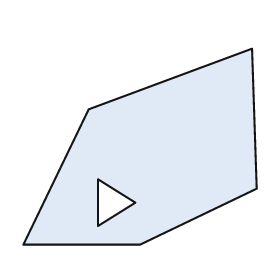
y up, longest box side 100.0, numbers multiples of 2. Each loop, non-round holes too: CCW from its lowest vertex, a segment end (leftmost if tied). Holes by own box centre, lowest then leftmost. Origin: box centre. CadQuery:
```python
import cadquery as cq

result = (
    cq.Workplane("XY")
    .moveTo(-50.0, -42.0)
    .lineTo(0.0, -42.0)
    .lineTo(50.0, -18.0)
    .lineTo(48.0, 42.0)
    .lineTo(-22.0, 16.0)
    .close()
    .moveTo(-18.0, -34.0)
    .lineTo(-2.0, -24.0)
    .lineTo(-18.0, -14.0)
    .close()
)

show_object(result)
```